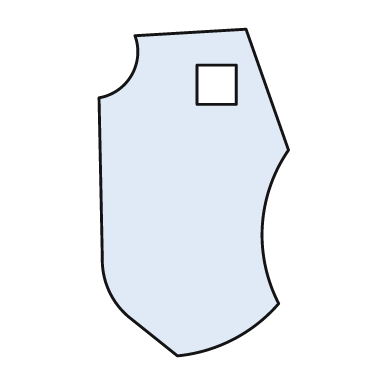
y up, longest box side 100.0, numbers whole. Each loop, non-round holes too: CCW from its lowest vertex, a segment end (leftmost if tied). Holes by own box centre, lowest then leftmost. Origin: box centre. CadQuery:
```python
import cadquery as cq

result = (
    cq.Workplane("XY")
    .moveTo(-5.0, -50.0)
    .threePointArc((12.0, -45.0), (26.0, -34.0))
    .threePointArc((21.0, -10.0), (29.0, 13.0))
    .lineTo(16.0, 50.0)
    .lineTo(-18.0, 48.0)
    .threePointArc((-19.0, 36.0), (-29.0, 29.0))
    .lineTo(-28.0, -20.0)
    .threePointArc((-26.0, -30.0), (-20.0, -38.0))
    .close()
    .moveTo(1.0, 27.0)
    .lineTo(13.0, 27.0)
    .lineTo(13.0, 39.0)
    .lineTo(1.0, 39.0)
    .close()
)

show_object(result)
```